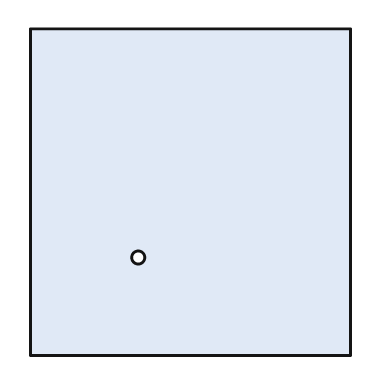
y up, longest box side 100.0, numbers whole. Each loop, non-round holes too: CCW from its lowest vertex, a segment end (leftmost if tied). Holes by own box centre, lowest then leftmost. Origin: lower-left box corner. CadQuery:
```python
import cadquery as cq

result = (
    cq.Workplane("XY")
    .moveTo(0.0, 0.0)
    .lineTo(98.0, 0.0)
    .lineTo(98.0, 100.0)
    .lineTo(0.0, 100.0)
    .close()
    .moveTo(33.0, 30.0)
    .circle(2.0)
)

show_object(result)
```